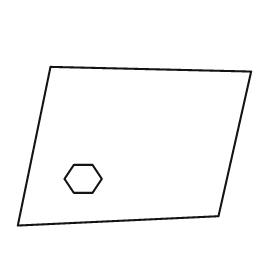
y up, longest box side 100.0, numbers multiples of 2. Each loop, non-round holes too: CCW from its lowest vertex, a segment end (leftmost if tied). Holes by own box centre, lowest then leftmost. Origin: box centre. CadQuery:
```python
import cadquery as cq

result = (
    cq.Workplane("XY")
    .moveTo(-50.0, -34.0)
    .lineTo(36.0, -30.0)
    .lineTo(50.0, 32.0)
    .lineTo(-36.0, 34.0)
    .close()
    .moveTo(-26.0, -20.0)
    .lineTo(-18.0, -20.0)
    .lineTo(-14.0, -14.0)
    .lineTo(-18.0, -8.0)
    .lineTo(-26.0, -8.0)
    .lineTo(-30.0, -14.0)
    .close()
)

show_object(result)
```